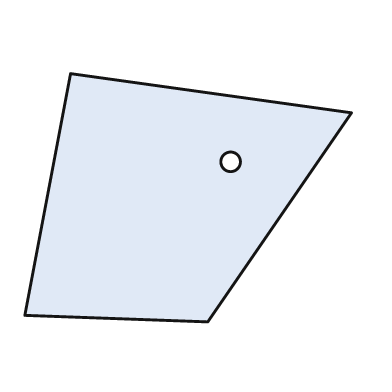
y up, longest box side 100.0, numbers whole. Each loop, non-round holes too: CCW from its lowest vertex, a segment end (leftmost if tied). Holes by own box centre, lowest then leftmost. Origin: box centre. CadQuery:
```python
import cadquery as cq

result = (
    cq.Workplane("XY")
    .moveTo(6.0, -38.0)
    .lineTo(50.0, 26.0)
    .lineTo(-36.0, 38.0)
    .lineTo(-50.0, -36.0)
    .close()
    .moveTo(13.0, 11.0)
    .circle(3.0)
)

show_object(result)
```